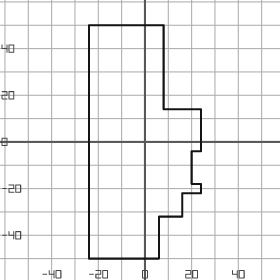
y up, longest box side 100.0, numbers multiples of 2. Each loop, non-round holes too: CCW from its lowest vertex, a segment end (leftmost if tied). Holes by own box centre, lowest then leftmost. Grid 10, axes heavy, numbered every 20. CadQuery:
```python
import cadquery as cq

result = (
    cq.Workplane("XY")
    .moveTo(-24.0, -50.0)
    .lineTo(6.0, -50.0)
    .lineTo(6.0, -32.0)
    .lineTo(16.0, -32.0)
    .lineTo(16.0, -22.0)
    .lineTo(24.0, -22.0)
    .lineTo(24.0, -18.0)
    .lineTo(20.0, -18.0)
    .lineTo(20.0, -4.0)
    .lineTo(24.0, -4.0)
    .lineTo(24.0, 14.0)
    .lineTo(8.0, 14.0)
    .lineTo(8.0, 50.0)
    .lineTo(-24.0, 50.0)
    .close()
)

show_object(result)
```